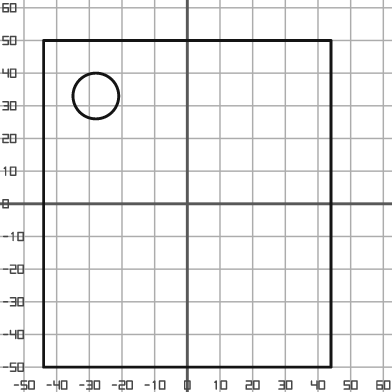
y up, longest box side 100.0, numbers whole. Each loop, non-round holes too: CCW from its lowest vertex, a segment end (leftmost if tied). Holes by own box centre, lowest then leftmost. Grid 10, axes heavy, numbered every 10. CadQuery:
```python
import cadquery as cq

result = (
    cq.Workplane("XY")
    .moveTo(-44.0, -50.0)
    .lineTo(44.0, -50.0)
    .lineTo(44.0, 50.0)
    .lineTo(-44.0, 50.0)
    .close()
    .moveTo(-28.0, 33.0)
    .circle(7.0)
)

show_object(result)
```